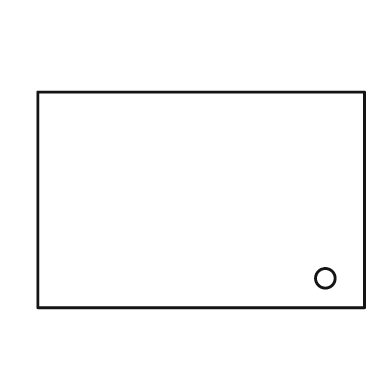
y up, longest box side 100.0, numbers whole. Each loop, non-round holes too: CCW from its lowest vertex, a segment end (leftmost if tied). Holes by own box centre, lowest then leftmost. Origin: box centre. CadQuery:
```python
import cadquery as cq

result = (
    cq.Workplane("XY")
    .moveTo(-50.0, -33.0)
    .lineTo(50.0, -33.0)
    .lineTo(50.0, 33.0)
    .lineTo(-50.0, 33.0)
    .close()
    .moveTo(38.0, -24.0)
    .circle(3.0)
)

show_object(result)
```